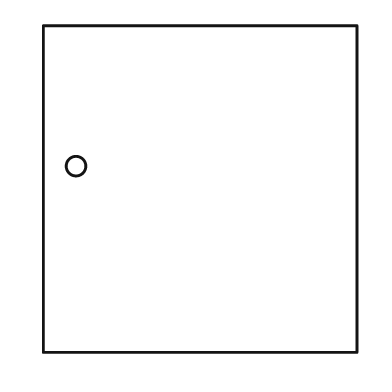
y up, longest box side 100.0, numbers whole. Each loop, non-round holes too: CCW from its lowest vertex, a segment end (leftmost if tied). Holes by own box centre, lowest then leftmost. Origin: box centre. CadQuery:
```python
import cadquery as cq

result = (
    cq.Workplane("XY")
    .moveTo(-48.0, -50.0)
    .lineTo(48.0, -50.0)
    .lineTo(48.0, 50.0)
    .lineTo(-48.0, 50.0)
    .close()
    .moveTo(-38.0, 7.0)
    .circle(3.0)
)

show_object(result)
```